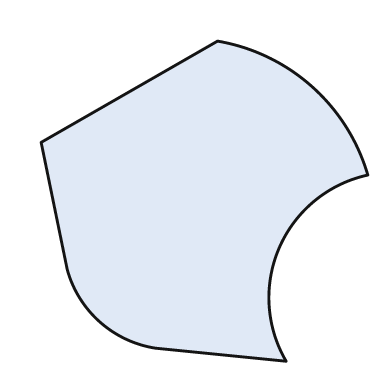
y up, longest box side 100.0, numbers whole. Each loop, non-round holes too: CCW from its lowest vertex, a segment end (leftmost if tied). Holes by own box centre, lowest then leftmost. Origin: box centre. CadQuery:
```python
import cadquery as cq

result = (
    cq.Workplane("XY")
    .moveTo(25.0, -49.0)
    .threePointArc((23.0, -14.0), (50.0, 8.0))
    .threePointArc((33.0, 35.0), (4.0, 49.0))
    .lineTo(-50.0, 18.0)
    .lineTo(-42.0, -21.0)
    .threePointArc((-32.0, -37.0), (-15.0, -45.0))
    .close()
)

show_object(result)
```